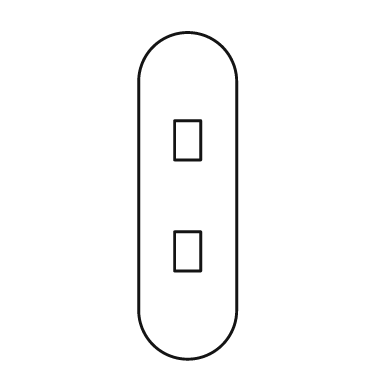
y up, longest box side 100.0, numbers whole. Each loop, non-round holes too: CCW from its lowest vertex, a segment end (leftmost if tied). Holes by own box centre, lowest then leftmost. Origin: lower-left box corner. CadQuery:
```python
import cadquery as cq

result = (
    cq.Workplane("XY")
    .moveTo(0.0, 15.0)
    .threePointArc((15.0, 0.0), (30.0, 15.0))
    .lineTo(30.0, 85.0)
    .threePointArc((15.0, 100.0), (0.0, 85.0))
    .close()
    .moveTo(11.0, 27.0)
    .lineTo(19.0, 27.0)
    .lineTo(19.0, 39.0)
    .lineTo(11.0, 39.0)
    .close()
    .moveTo(11.0, 61.0)
    .lineTo(19.0, 61.0)
    .lineTo(19.0, 73.0)
    .lineTo(11.0, 73.0)
    .close()
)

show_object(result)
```